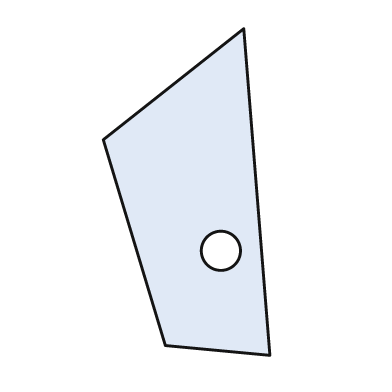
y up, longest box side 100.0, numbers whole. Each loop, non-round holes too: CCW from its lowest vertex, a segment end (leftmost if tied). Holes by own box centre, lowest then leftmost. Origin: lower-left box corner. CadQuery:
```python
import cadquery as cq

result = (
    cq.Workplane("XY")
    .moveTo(51.0, 0.0)
    .lineTo(43.0, 100.0)
    .lineTo(0.0, 66.0)
    .lineTo(19.0, 3.0)
    .close()
    .moveTo(36.0, 32.0)
    .circle(6.0)
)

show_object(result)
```